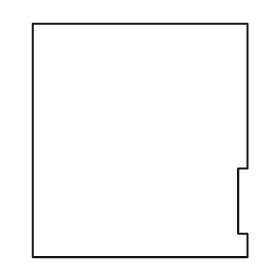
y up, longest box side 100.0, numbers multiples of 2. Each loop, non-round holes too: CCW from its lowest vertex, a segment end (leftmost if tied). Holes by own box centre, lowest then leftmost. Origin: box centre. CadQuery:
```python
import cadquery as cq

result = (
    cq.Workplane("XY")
    .moveTo(-46.0, -50.0)
    .lineTo(46.0, -50.0)
    .lineTo(46.0, -40.0)
    .lineTo(42.0, -40.0)
    .lineTo(42.0, -12.0)
    .lineTo(46.0, -12.0)
    .lineTo(46.0, 50.0)
    .lineTo(-46.0, 50.0)
    .close()
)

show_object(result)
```